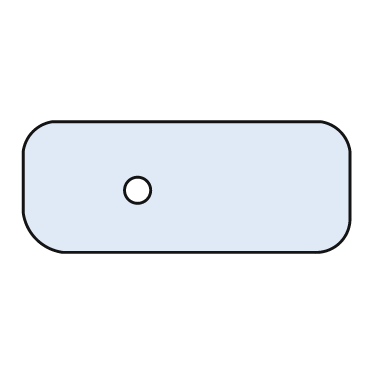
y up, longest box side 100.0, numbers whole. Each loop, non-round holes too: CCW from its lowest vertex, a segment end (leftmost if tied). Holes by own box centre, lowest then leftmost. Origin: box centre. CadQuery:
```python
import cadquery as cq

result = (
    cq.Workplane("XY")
    .moveTo(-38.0, -20.0)
    .lineTo(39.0, -20.0)
    .threePointArc((47.0, -17.0), (50.0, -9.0))
    .lineTo(50.0, 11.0)
    .threePointArc((47.0, 17.0), (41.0, 20.0))
    .lineTo(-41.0, 20.0)
    .threePointArc((-47.0, 17.0), (-50.0, 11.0))
    .lineTo(-50.0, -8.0)
    .threePointArc((-46.0, -16.0), (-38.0, -20.0))
    .close()
    .moveTo(-15.0, -1.0)
    .circle(4.0)
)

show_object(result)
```